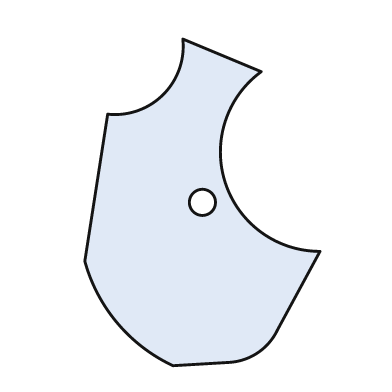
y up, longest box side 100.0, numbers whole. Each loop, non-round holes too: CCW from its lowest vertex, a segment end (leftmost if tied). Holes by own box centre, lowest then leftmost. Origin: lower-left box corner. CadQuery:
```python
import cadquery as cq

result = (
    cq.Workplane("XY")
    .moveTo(27.0, 0.0)
    .lineTo(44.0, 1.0)
    .threePointArc((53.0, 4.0), (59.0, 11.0))
    .lineTo(72.0, 35.0)
    .threePointArc((43.0, 56.0), (54.0, 90.0))
    .lineTo(30.0, 100.0)
    .threePointArc((24.0, 83.0), (7.0, 77.0))
    .lineTo(0.0, 32.0)
    .threePointArc((10.0, 13.0), (27.0, 0.0))
    .close()
    .moveTo(36.0, 50.0)
    .circle(4.0)
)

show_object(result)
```